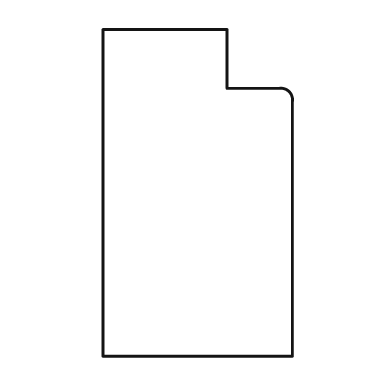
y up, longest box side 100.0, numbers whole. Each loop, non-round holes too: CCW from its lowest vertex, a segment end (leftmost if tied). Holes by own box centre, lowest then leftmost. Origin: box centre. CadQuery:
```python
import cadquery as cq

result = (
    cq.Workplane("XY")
    .moveTo(-29.0, -50.0)
    .lineTo(29.0, -50.0)
    .lineTo(29.0, 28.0)
    .threePointArc((28.0, 31.0), (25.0, 32.0))
    .lineTo(9.0, 32.0)
    .lineTo(9.0, 50.0)
    .lineTo(-29.0, 50.0)
    .close()
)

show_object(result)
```